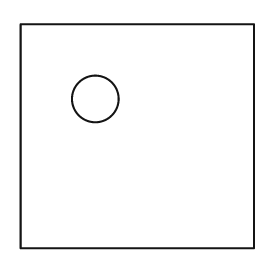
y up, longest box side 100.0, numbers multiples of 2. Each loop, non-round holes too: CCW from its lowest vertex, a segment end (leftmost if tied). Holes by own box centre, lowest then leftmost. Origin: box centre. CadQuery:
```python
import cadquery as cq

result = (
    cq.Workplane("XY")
    .moveTo(-50.0, -48.0)
    .lineTo(50.0, -48.0)
    .lineTo(50.0, 48.0)
    .lineTo(-50.0, 48.0)
    .close()
    .moveTo(-18.0, 16.0)
    .circle(10.0)
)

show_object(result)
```